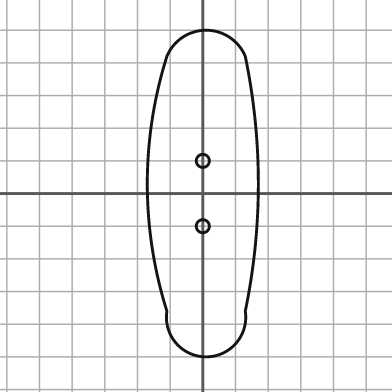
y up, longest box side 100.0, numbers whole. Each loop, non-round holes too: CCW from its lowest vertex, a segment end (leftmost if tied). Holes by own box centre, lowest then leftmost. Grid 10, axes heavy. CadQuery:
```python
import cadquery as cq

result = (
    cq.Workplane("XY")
    .moveTo(-11.0, -36.0)
    .threePointArc((1.0, -50.0), (13.0, -36.0))
    .threePointArc((17.0, 3.0), (13.0, 42.0))
    .threePointArc((1.0, 50.0), (-11.0, 42.0))
    .threePointArc((-17.0, 3.0), (-11.0, -36.0))
    .close()
    .moveTo(0.0, -10.0)
    .circle(2.0)
    .moveTo(0.0, 10.0)
    .circle(2.0)
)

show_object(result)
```